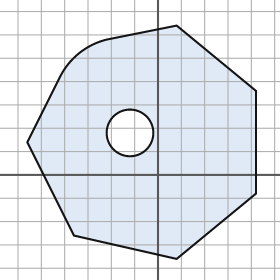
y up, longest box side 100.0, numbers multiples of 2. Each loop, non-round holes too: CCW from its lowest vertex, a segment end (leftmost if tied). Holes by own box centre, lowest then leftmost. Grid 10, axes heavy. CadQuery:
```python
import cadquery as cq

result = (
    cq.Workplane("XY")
    .moveTo(8.0, -36.0)
    .lineTo(42.0, -8.0)
    .lineTo(42.0, 36.0)
    .lineTo(8.0, 64.0)
    .lineTo(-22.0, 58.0)
    .threePointArc((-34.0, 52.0), (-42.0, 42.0))
    .lineTo(-56.0, 14.0)
    .lineTo(-36.0, -26.0)
    .close()
    .moveTo(-12.0, 18.0)
    .circle(10.0)
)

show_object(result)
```